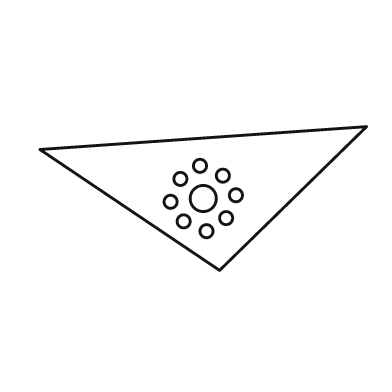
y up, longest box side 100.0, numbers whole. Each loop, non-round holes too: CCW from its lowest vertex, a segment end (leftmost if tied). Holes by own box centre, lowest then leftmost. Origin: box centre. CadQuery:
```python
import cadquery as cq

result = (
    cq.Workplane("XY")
    .moveTo(5.0, -22.0)
    .lineTo(50.0, 22.0)
    .lineTo(-50.0, 15.0)
    .close()
    .moveTo(1.0, -10.0)
    .circle(2.0)
    .moveTo(-6.0, -7.0)
    .circle(2.0)
    .moveTo(7.0, -6.0)
    .circle(2.0)
    .moveTo(-10.0, -1.0)
    .circle(2.0)
    .moveTo(0.0, 0.0)
    .circle(4.0)
    .moveTo(10.0, 1.0)
    .circle(2.0)
    .moveTo(-7.0, 6.0)
    .circle(2.0)
    .moveTo(6.0, 7.0)
    .circle(2.0)
    .moveTo(-1.0, 10.0)
    .circle(2.0)
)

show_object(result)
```